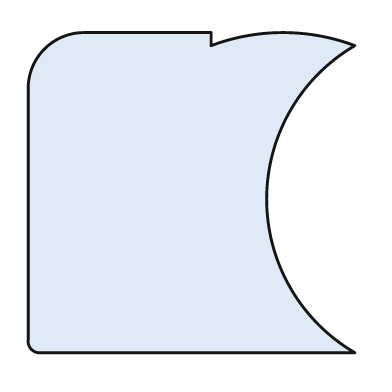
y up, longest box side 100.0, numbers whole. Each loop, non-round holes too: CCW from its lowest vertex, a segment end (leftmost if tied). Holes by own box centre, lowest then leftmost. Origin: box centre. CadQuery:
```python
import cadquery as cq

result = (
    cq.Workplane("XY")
    .moveTo(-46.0, -49.0)
    .lineTo(50.0, -49.0)
    .threePointArc((23.0, -2.0), (50.0, 45.0))
    .threePointArc((28.0, 49.0), (6.0, 45.0))
    .lineTo(6.0, 49.0)
    .lineTo(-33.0, 49.0)
    .threePointArc((-45.0, 44.0), (-50.0, 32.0))
    .lineTo(-50.0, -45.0)
    .threePointArc((-49.0, -48.0), (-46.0, -49.0))
    .close()
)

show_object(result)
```